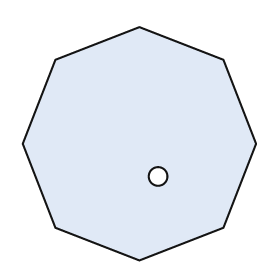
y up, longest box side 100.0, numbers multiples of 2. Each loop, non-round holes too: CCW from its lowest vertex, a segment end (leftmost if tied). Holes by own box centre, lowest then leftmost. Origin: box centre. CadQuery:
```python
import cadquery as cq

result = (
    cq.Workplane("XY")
    .moveTo(0.0, -50.0)
    .lineTo(36.0, -36.0)
    .lineTo(50.0, 0.0)
    .lineTo(36.0, 36.0)
    .lineTo(0.0, 50.0)
    .lineTo(-36.0, 36.0)
    .lineTo(-50.0, 0.0)
    .lineTo(-36.0, -36.0)
    .close()
    .moveTo(8.0, -14.0)
    .circle(4.0)
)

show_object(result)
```